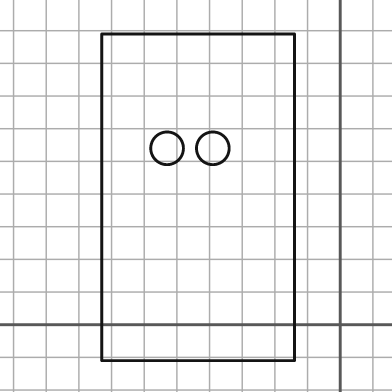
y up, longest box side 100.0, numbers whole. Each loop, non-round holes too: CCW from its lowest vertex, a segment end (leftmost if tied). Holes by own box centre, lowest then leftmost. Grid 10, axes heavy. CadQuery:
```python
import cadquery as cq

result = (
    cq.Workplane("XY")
    .moveTo(-73.0, -11.0)
    .lineTo(-14.0, -11.0)
    .lineTo(-14.0, 89.0)
    .lineTo(-73.0, 89.0)
    .close()
    .moveTo(-53.0, 54.0)
    .circle(5.0)
    .moveTo(-39.0, 54.0)
    .circle(5.0)
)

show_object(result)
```